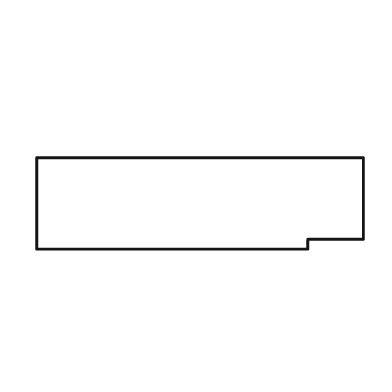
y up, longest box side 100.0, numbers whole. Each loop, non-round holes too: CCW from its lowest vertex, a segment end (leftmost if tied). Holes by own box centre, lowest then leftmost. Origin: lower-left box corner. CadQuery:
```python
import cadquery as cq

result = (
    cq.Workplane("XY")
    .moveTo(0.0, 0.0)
    .lineTo(83.0, 0.0)
    .lineTo(83.0, 3.0)
    .lineTo(100.0, 3.0)
    .lineTo(100.0, 28.0)
    .lineTo(0.0, 28.0)
    .close()
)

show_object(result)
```